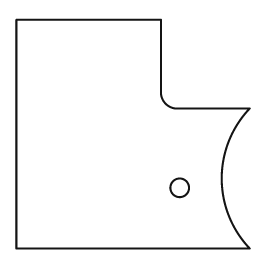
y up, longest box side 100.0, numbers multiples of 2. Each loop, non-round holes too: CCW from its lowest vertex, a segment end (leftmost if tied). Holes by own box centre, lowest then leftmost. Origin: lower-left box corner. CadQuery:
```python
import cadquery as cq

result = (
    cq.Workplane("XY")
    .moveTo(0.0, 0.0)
    .lineTo(100.0, 0.0)
    .threePointArc((88.0, 30.0), (100.0, 60.0))
    .lineTo(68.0, 60.0)
    .threePointArc((64.0, 62.0), (62.0, 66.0))
    .lineTo(62.0, 98.0)
    .lineTo(0.0, 98.0)
    .close()
    .moveTo(70.0, 26.0)
    .circle(4.0)
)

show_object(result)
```